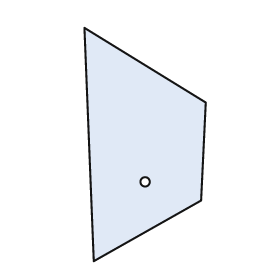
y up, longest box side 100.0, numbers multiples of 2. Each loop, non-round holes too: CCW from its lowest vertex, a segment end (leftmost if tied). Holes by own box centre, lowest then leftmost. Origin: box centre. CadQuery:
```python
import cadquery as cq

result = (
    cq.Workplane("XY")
    .moveTo(-22.0, -50.0)
    .lineTo(24.0, -24.0)
    .lineTo(26.0, 18.0)
    .lineTo(-26.0, 50.0)
    .close()
    .moveTo(0.0, -16.0)
    .circle(2.0)
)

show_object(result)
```